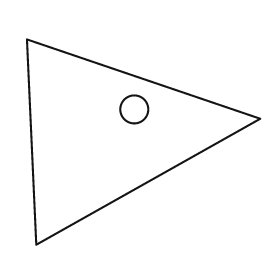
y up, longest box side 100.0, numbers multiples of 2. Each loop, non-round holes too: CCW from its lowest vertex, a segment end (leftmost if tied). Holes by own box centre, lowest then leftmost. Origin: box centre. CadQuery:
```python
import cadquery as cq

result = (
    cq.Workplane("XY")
    .moveTo(-46.0, -44.0)
    .lineTo(50.0, 10.0)
    .lineTo(-50.0, 44.0)
    .close()
    .moveTo(-4.0, 14.0)
    .circle(6.0)
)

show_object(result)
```